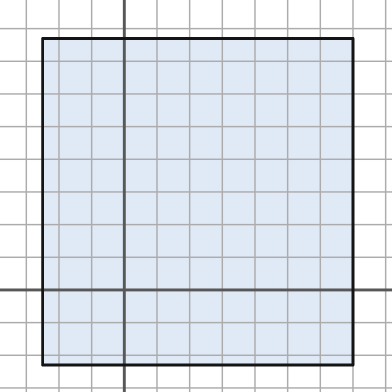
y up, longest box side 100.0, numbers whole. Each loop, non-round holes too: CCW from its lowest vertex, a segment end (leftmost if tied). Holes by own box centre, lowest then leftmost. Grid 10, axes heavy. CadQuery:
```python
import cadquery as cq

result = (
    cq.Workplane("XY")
    .moveTo(-25.0, -23.0)
    .lineTo(70.0, -23.0)
    .lineTo(70.0, 77.0)
    .lineTo(-25.0, 77.0)
    .close()
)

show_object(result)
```